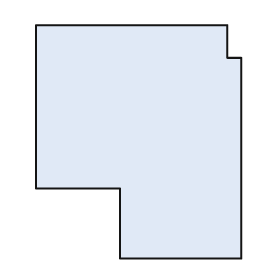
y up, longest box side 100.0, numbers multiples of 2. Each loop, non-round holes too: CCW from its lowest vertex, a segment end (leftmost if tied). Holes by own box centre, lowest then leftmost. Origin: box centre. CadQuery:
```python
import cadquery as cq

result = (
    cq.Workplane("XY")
    .moveTo(-8.0, -50.0)
    .lineTo(44.0, -50.0)
    .lineTo(44.0, 36.0)
    .lineTo(38.0, 36.0)
    .lineTo(38.0, 50.0)
    .lineTo(-44.0, 50.0)
    .lineTo(-44.0, -20.0)
    .lineTo(-8.0, -20.0)
    .close()
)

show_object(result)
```